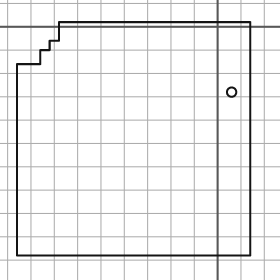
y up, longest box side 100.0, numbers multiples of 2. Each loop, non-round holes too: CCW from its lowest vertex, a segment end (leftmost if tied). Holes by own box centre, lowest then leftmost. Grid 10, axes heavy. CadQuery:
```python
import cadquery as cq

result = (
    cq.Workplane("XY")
    .moveTo(-86.0, -98.0)
    .lineTo(14.0, -98.0)
    .lineTo(14.0, 2.0)
    .lineTo(-68.0, 2.0)
    .lineTo(-68.0, -6.0)
    .lineTo(-72.0, -6.0)
    .lineTo(-72.0, -10.0)
    .lineTo(-76.0, -10.0)
    .lineTo(-76.0, -16.0)
    .lineTo(-86.0, -16.0)
    .close()
    .moveTo(6.0, -28.0)
    .circle(2.0)
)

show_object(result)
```